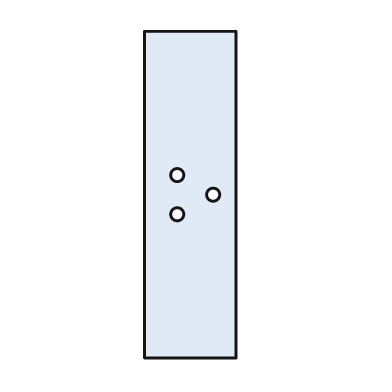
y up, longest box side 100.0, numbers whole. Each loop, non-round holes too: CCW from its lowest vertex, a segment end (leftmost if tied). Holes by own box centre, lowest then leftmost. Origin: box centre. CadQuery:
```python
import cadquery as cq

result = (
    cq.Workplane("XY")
    .moveTo(-14.0, -50.0)
    .lineTo(14.0, -50.0)
    .lineTo(14.0, 50.0)
    .lineTo(-14.0, 50.0)
    .close()
    .moveTo(-4.0, -6.0)
    .circle(2.0)
    .moveTo(7.0, 0.0)
    .circle(2.0)
    .moveTo(-4.0, 6.0)
    .circle(2.0)
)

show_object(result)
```